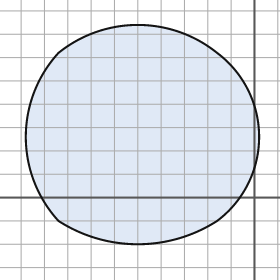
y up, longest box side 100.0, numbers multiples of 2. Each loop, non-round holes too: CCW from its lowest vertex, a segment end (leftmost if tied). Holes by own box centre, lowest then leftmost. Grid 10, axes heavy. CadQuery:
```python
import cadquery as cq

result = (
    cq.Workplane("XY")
    .moveTo(-84.0, -10.0)
    .threePointArc((-50.0, -20.0), (-16.0, -10.0))
    .threePointArc((2.0, 26.0), (-16.0, 62.0))
    .threePointArc((-50.0, 74.0), (-84.0, 62.0))
    .threePointArc((-98.0, 26.0), (-84.0, -10.0))
    .close()
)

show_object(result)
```